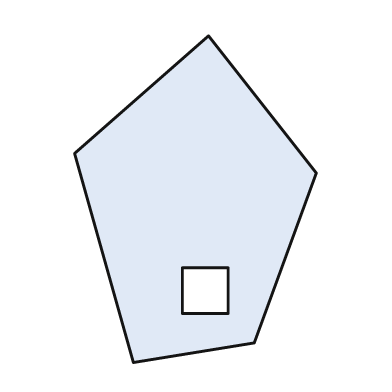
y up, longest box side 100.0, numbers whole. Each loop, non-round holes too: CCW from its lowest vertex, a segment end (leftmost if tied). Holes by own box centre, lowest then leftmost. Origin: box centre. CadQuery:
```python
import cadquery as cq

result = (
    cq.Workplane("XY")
    .moveTo(-19.0, -50.0)
    .lineTo(18.0, -44.0)
    .lineTo(37.0, 8.0)
    .lineTo(4.0, 50.0)
    .lineTo(-37.0, 14.0)
    .close()
    .moveTo(-4.0, -35.0)
    .lineTo(10.0, -35.0)
    .lineTo(10.0, -21.0)
    .lineTo(-4.0, -21.0)
    .close()
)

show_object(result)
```